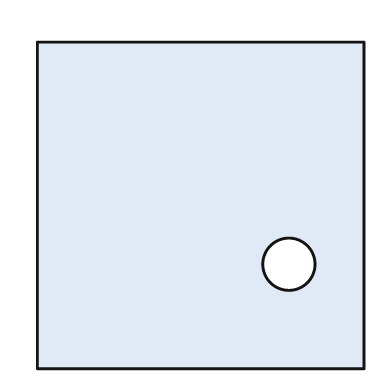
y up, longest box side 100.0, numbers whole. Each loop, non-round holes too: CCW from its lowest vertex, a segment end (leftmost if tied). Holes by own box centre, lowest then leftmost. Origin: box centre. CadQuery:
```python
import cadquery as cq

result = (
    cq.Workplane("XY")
    .moveTo(-50.0, -50.0)
    .lineTo(50.0, -50.0)
    .lineTo(50.0, 50.0)
    .lineTo(-50.0, 50.0)
    .close()
    .moveTo(27.0, -18.0)
    .circle(8.0)
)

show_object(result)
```